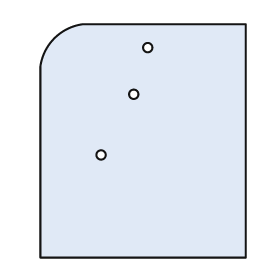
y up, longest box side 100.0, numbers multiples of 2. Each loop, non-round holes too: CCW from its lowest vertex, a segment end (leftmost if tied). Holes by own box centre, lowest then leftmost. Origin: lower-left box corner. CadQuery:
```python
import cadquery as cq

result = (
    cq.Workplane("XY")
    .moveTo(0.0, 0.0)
    .lineTo(88.0, 0.0)
    .lineTo(88.0, 100.0)
    .lineTo(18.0, 100.0)
    .threePointArc((6.0, 94.0), (0.0, 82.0))
    .close()
    .moveTo(26.0, 44.0)
    .circle(2.0)
    .moveTo(40.0, 70.0)
    .circle(2.0)
    .moveTo(46.0, 90.0)
    .circle(2.0)
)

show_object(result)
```